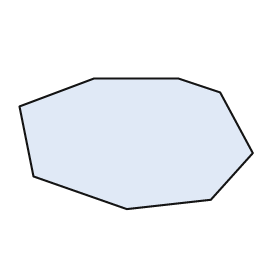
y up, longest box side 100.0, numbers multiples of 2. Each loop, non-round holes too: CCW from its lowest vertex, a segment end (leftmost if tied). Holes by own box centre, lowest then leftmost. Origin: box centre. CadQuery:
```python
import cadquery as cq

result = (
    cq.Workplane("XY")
    .moveTo(-4.0, -28.0)
    .lineTo(32.0, -24.0)
    .lineTo(50.0, -4.0)
    .lineTo(36.0, 22.0)
    .lineTo(18.0, 28.0)
    .lineTo(-18.0, 28.0)
    .lineTo(-50.0, 16.0)
    .lineTo(-44.0, -14.0)
    .close()
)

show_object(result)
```